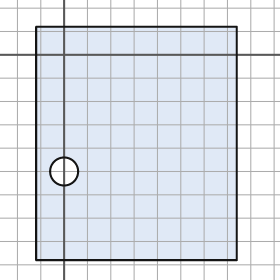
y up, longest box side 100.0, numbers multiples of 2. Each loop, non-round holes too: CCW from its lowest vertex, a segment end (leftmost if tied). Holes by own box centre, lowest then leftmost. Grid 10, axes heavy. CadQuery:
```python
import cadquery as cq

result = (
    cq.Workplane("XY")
    .moveTo(-12.0, -88.0)
    .lineTo(74.0, -88.0)
    .lineTo(74.0, 12.0)
    .lineTo(-12.0, 12.0)
    .close()
    .moveTo(0.0, -50.0)
    .circle(6.0)
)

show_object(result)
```